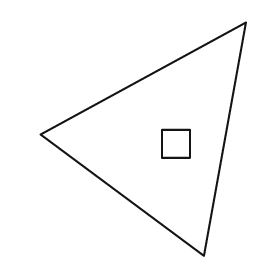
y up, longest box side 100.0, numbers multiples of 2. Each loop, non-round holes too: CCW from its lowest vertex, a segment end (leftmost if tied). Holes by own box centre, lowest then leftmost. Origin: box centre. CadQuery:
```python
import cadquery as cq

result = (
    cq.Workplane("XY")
    .moveTo(26.0, -50.0)
    .lineTo(44.0, 50.0)
    .lineTo(-44.0, 2.0)
    .close()
    .moveTo(8.0, -8.0)
    .lineTo(20.0, -8.0)
    .lineTo(20.0, 4.0)
    .lineTo(8.0, 4.0)
    .close()
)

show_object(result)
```